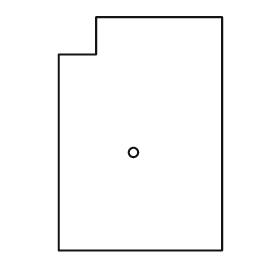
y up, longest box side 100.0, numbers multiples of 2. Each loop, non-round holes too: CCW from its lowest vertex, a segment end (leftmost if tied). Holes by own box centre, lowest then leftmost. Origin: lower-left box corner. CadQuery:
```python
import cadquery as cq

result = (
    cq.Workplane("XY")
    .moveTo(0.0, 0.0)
    .lineTo(70.0, 0.0)
    .lineTo(70.0, 100.0)
    .lineTo(16.0, 100.0)
    .lineTo(16.0, 84.0)
    .lineTo(0.0, 84.0)
    .close()
    .moveTo(32.0, 42.0)
    .circle(2.0)
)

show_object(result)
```